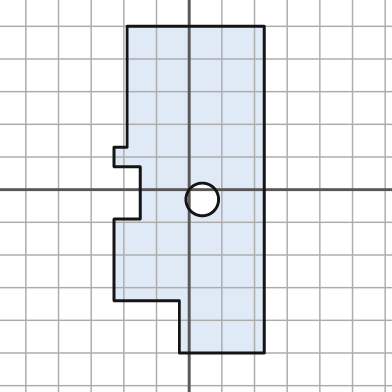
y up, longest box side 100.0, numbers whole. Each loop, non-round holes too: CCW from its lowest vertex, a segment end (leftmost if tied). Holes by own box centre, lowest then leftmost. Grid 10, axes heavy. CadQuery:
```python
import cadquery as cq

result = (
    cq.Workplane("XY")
    .moveTo(-3.0, -50.0)
    .lineTo(23.0, -50.0)
    .lineTo(23.0, 50.0)
    .lineTo(-19.0, 50.0)
    .lineTo(-19.0, 13.0)
    .lineTo(-23.0, 13.0)
    .lineTo(-23.0, 7.0)
    .lineTo(-15.0, 7.0)
    .lineTo(-15.0, -9.0)
    .lineTo(-23.0, -9.0)
    .lineTo(-23.0, -34.0)
    .lineTo(-3.0, -34.0)
    .close()
    .moveTo(4.0, -3.0)
    .circle(5.0)
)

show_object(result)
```